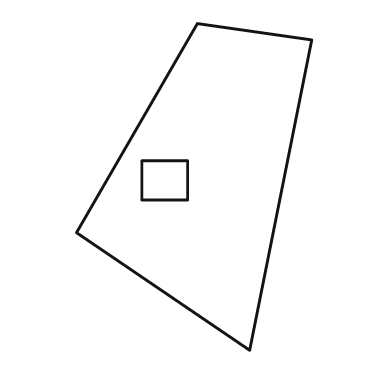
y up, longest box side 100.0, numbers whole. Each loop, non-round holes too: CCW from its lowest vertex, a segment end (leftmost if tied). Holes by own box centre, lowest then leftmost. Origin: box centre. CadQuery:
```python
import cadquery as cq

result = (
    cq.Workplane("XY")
    .moveTo(17.0, -50.0)
    .lineTo(36.0, 45.0)
    .lineTo(1.0, 50.0)
    .lineTo(-36.0, -14.0)
    .close()
    .moveTo(-16.0, -4.0)
    .lineTo(-2.0, -4.0)
    .lineTo(-2.0, 8.0)
    .lineTo(-16.0, 8.0)
    .close()
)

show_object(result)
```